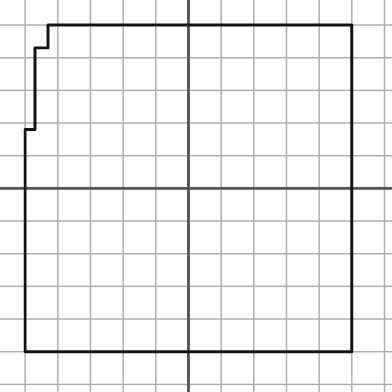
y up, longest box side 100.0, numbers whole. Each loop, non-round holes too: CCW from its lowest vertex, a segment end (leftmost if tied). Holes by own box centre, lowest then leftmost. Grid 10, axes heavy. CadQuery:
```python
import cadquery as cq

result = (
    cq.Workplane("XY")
    .moveTo(-50.0, -50.0)
    .lineTo(50.0, -50.0)
    .lineTo(50.0, 50.0)
    .lineTo(-43.0, 50.0)
    .lineTo(-43.0, 43.0)
    .lineTo(-47.0, 43.0)
    .lineTo(-47.0, 18.0)
    .lineTo(-50.0, 18.0)
    .close()
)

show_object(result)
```